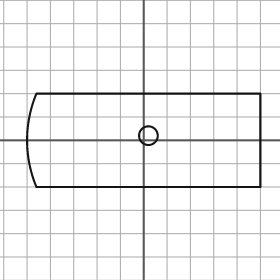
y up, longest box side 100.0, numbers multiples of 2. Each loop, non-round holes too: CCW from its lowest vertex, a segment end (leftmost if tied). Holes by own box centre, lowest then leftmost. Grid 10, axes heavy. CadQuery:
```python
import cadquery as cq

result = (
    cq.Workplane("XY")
    .moveTo(-46.0, -20.0)
    .lineTo(50.0, -20.0)
    .lineTo(50.0, 20.0)
    .lineTo(-46.0, 20.0)
    .threePointArc((-50.0, 0.0), (-46.0, -20.0))
    .close()
    .moveTo(2.0, 2.0)
    .circle(4.0)
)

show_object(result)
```